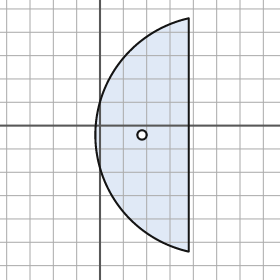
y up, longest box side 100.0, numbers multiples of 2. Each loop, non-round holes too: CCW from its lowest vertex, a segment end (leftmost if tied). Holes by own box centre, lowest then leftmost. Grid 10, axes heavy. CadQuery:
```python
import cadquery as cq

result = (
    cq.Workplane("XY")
    .moveTo(38.0, -54.0)
    .lineTo(38.0, 46.0)
    .threePointArc((-2.0, -4.0), (38.0, -54.0))
    .close()
    .moveTo(18.0, -4.0)
    .circle(2.0)
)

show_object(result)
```